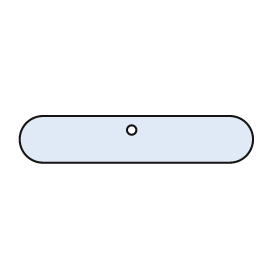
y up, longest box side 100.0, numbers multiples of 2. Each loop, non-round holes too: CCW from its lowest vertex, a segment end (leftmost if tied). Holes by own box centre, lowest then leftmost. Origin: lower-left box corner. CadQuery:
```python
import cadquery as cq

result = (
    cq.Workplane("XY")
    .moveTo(10.0, 0.0)
    .lineTo(90.0, 0.0)
    .threePointArc((100.0, 10.0), (90.0, 20.0))
    .lineTo(10.0, 20.0)
    .threePointArc((0.0, 10.0), (10.0, 0.0))
    .close()
    .moveTo(48.0, 14.0)
    .circle(2.0)
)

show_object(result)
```